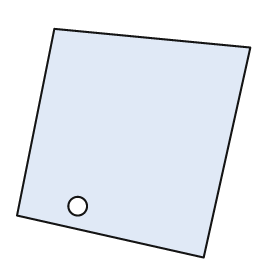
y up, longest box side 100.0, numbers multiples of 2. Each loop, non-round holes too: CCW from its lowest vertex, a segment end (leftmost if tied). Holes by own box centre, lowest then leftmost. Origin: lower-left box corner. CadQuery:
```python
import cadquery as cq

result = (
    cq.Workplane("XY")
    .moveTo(80.0, 0.0)
    .lineTo(100.0, 90.0)
    .lineTo(16.0, 98.0)
    .lineTo(0.0, 18.0)
    .close()
    .moveTo(26.0, 22.0)
    .circle(4.0)
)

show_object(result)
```